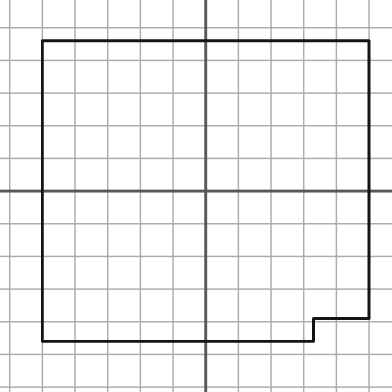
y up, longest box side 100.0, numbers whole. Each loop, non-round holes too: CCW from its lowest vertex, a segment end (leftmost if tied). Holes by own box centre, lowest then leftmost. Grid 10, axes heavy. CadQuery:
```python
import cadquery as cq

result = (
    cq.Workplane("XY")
    .moveTo(-50.0, -46.0)
    .lineTo(33.0, -46.0)
    .lineTo(33.0, -39.0)
    .lineTo(50.0, -39.0)
    .lineTo(50.0, 46.0)
    .lineTo(-50.0, 46.0)
    .close()
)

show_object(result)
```